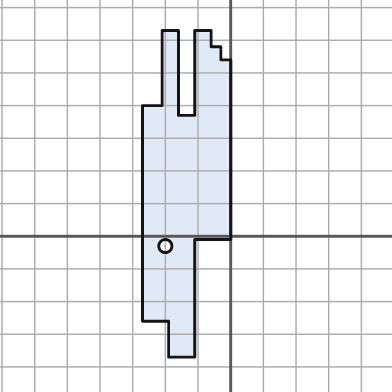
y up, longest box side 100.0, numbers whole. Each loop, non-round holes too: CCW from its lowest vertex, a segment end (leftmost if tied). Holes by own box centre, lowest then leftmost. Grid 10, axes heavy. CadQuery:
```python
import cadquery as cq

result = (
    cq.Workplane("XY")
    .moveTo(-19.0, -37.0)
    .lineTo(-11.0, -37.0)
    .lineTo(-11.0, -1.0)
    .lineTo(0.0, -1.0)
    .lineTo(0.0, 54.0)
    .lineTo(-3.0, 54.0)
    .lineTo(-3.0, 58.0)
    .lineTo(-6.0, 58.0)
    .lineTo(-6.0, 63.0)
    .lineTo(-11.0, 63.0)
    .lineTo(-11.0, 37.0)
    .lineTo(-16.0, 37.0)
    .lineTo(-16.0, 63.0)
    .lineTo(-21.0, 63.0)
    .lineTo(-21.0, 40.0)
    .lineTo(-27.0, 40.0)
    .lineTo(-27.0, -26.0)
    .lineTo(-19.0, -26.0)
    .close()
    .moveTo(-20.0, -3.0)
    .circle(2.0)
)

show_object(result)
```